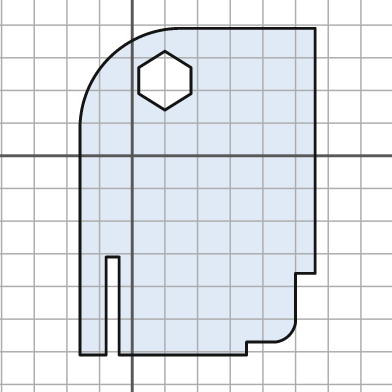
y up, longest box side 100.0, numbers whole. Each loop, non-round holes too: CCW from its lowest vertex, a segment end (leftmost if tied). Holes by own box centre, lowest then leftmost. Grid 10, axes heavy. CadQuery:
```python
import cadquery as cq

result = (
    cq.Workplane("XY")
    .moveTo(-16.0, -61.0)
    .lineTo(-8.0, -61.0)
    .lineTo(-8.0, -31.0)
    .lineTo(-4.0, -31.0)
    .lineTo(-4.0, -61.0)
    .lineTo(35.0, -61.0)
    .lineTo(35.0, -57.0)
    .lineTo(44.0, -57.0)
    .threePointArc((48.0, -55.0), (50.0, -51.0))
    .lineTo(50.0, -36.0)
    .lineTo(56.0, -36.0)
    .lineTo(56.0, 39.0)
    .lineTo(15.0, 39.0)
    .threePointArc((-7.0, 30.0), (-16.0, 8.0))
    .close()
    .moveTo(10.0, 14.0)
    .lineTo(18.0, 19.0)
    .lineTo(18.0, 27.0)
    .lineTo(10.0, 32.0)
    .lineTo(2.0, 27.0)
    .lineTo(2.0, 19.0)
    .close()
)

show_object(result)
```